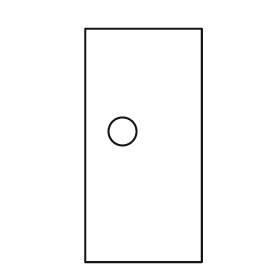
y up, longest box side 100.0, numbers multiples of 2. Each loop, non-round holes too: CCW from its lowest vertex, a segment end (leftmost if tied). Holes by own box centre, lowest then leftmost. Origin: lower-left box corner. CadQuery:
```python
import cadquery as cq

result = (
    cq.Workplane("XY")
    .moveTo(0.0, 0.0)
    .lineTo(50.0, 0.0)
    .lineTo(50.0, 100.0)
    .lineTo(0.0, 100.0)
    .close()
    .moveTo(16.0, 56.0)
    .circle(6.0)
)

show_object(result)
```